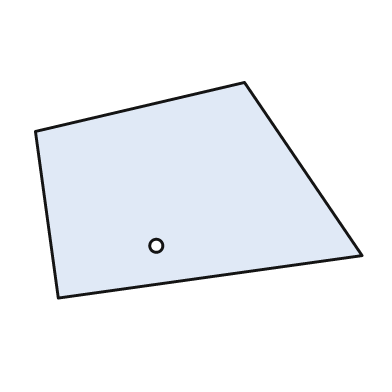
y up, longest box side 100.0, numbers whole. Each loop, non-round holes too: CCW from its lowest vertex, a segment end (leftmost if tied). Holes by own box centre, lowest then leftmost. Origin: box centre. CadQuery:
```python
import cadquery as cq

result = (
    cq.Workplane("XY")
    .moveTo(-43.0, -33.0)
    .lineTo(50.0, -20.0)
    .lineTo(14.0, 33.0)
    .lineTo(-50.0, 18.0)
    .close()
    .moveTo(-13.0, -17.0)
    .circle(2.0)
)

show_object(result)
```